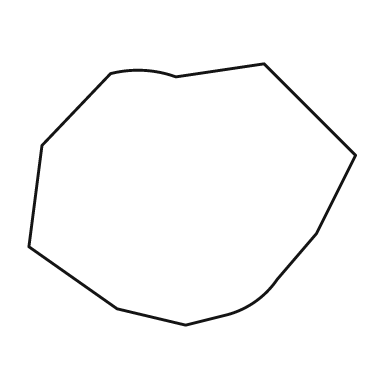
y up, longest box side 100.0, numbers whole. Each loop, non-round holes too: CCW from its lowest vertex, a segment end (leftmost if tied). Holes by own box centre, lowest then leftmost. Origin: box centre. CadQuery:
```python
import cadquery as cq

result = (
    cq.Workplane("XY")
    .moveTo(-2.0, -40.0)
    .lineTo(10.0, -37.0)
    .threePointArc((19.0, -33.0), (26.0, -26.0))
    .lineTo(38.0, -12.0)
    .lineTo(50.0, 12.0)
    .lineTo(22.0, 40.0)
    .lineTo(-5.0, 36.0)
    .threePointArc((-15.0, 38.0), (-25.0, 37.0))
    .lineTo(-46.0, 15.0)
    .lineTo(-50.0, -16.0)
    .lineTo(-23.0, -35.0)
    .close()
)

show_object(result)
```